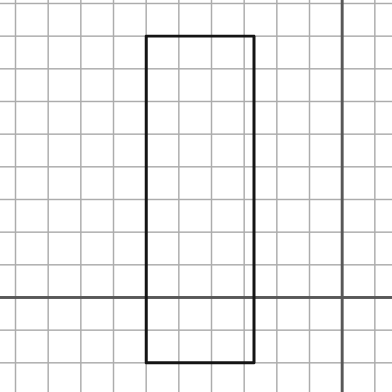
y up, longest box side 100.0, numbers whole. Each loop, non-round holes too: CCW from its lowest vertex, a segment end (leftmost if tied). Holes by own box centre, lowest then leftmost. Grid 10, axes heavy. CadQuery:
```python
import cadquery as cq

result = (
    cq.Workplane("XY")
    .moveTo(-60.0, -20.0)
    .lineTo(-27.0, -20.0)
    .lineTo(-27.0, 80.0)
    .lineTo(-60.0, 80.0)
    .close()
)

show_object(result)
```